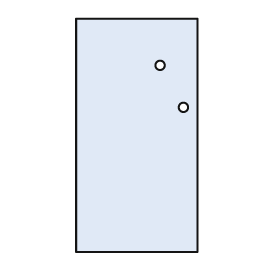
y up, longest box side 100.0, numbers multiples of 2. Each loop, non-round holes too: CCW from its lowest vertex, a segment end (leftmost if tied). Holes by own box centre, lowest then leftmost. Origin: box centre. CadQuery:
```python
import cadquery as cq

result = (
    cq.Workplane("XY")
    .moveTo(-26.0, -50.0)
    .lineTo(26.0, -50.0)
    .lineTo(26.0, 50.0)
    .lineTo(-26.0, 50.0)
    .close()
    .moveTo(20.0, 12.0)
    .circle(2.0)
    .moveTo(10.0, 30.0)
    .circle(2.0)
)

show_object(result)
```